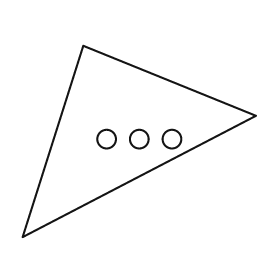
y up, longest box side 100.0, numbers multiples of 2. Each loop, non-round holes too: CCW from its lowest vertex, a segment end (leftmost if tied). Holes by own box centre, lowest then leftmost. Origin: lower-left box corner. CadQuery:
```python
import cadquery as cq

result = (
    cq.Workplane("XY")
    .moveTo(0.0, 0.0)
    .lineTo(100.0, 52.0)
    .lineTo(26.0, 82.0)
    .close()
    .moveTo(36.0, 42.0)
    .circle(4.0)
    .moveTo(50.0, 42.0)
    .circle(4.0)
    .moveTo(64.0, 42.0)
    .circle(4.0)
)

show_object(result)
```